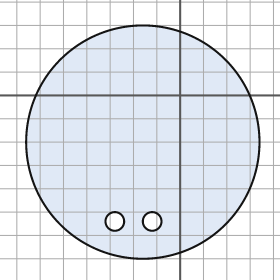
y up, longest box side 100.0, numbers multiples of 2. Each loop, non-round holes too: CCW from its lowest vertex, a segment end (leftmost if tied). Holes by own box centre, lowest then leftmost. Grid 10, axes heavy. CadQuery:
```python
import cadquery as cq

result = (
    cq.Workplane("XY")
    .moveTo(-16.0, -20.0)
    .circle(50.0)
    .moveTo(-28.0, -54.0)
    .circle(4.0)
    .moveTo(-12.0, -54.0)
    .circle(4.0)
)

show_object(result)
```